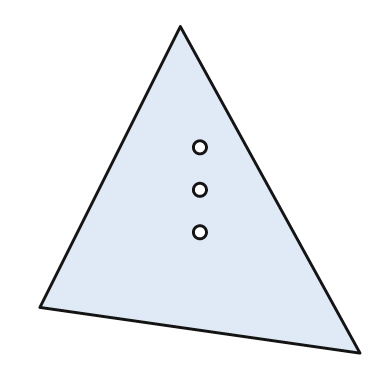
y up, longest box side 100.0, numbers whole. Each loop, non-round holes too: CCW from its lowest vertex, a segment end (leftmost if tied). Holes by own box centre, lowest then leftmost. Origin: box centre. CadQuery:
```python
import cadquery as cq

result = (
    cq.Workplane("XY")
    .moveTo(49.0, -50.0)
    .lineTo(-6.0, 50.0)
    .lineTo(-49.0, -36.0)
    .close()
    .moveTo(0.0, -13.0)
    .circle(2.0)
    .moveTo(0.0, 0.0)
    .circle(2.0)
    .moveTo(0.0, 13.0)
    .circle(2.0)
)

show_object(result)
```